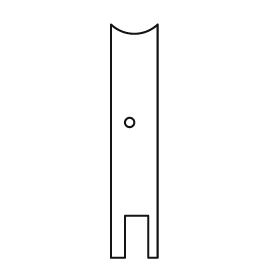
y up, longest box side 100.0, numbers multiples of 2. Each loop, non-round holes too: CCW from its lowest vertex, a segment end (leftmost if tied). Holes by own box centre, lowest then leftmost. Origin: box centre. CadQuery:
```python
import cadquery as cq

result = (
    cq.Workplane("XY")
    .moveTo(-10.0, -50.0)
    .lineTo(-4.0, -50.0)
    .lineTo(-4.0, -32.0)
    .lineTo(6.0, -32.0)
    .lineTo(6.0, -50.0)
    .lineTo(10.0, -50.0)
    .lineTo(10.0, 50.0)
    .threePointArc((0.0, 46.0), (-10.0, 50.0))
    .close()
    .moveTo(-2.0, 8.0)
    .circle(2.0)
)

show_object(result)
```